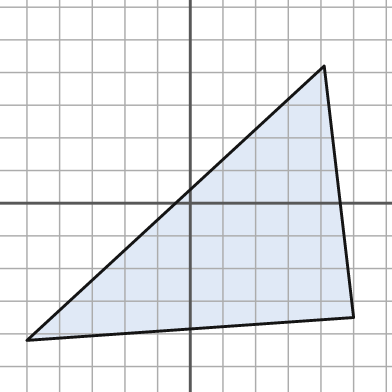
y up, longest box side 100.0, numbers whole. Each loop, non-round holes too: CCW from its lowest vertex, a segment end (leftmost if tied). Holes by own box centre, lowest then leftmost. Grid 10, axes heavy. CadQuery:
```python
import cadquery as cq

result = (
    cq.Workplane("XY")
    .moveTo(-50.0, -42.0)
    .lineTo(50.0, -35.0)
    .lineTo(41.0, 42.0)
    .close()
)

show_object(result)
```